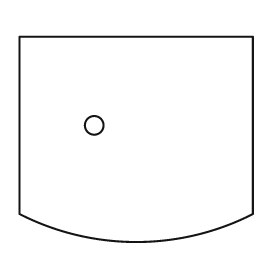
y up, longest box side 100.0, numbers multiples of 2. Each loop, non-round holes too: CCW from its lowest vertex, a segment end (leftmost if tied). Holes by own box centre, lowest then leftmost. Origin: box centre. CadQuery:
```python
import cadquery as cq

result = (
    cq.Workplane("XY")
    .moveTo(-50.0, -32.0)
    .threePointArc((0.0, -44.0), (50.0, -32.0))
    .lineTo(50.0, 44.0)
    .lineTo(-50.0, 44.0)
    .close()
    .moveTo(-18.0, 6.0)
    .circle(4.0)
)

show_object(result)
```